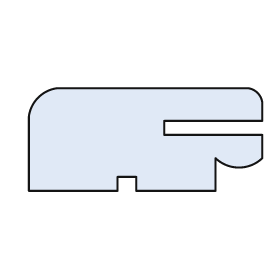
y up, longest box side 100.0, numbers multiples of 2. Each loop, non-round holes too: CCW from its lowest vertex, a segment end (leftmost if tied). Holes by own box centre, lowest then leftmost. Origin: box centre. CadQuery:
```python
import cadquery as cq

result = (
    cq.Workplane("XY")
    .moveTo(-50.0, -22.0)
    .lineTo(-12.0, -22.0)
    .lineTo(-12.0, -16.0)
    .lineTo(-4.0, -16.0)
    .lineTo(-4.0, -22.0)
    .lineTo(30.0, -22.0)
    .lineTo(30.0, -8.0)
    .threePointArc((40.0, -12.0), (50.0, -8.0))
    .lineTo(50.0, 2.0)
    .lineTo(8.0, 2.0)
    .lineTo(8.0, 8.0)
    .lineTo(50.0, 8.0)
    .lineTo(50.0, 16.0)
    .threePointArc((48.0, 20.0), (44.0, 22.0))
    .lineTo(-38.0, 22.0)
    .threePointArc((-46.0, 18.0), (-50.0, 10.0))
    .close()
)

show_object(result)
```